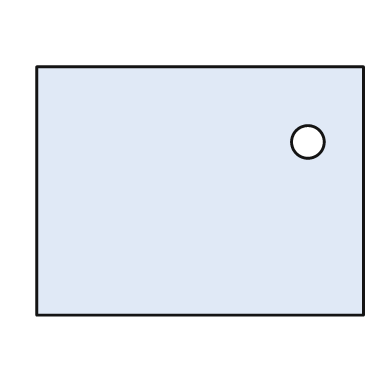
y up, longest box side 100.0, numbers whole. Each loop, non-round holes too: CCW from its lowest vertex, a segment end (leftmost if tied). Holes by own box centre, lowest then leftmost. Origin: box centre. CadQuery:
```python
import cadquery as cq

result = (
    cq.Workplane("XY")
    .moveTo(-50.0, -38.0)
    .lineTo(50.0, -38.0)
    .lineTo(50.0, 38.0)
    .lineTo(-50.0, 38.0)
    .close()
    .moveTo(33.0, 15.0)
    .circle(5.0)
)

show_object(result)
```